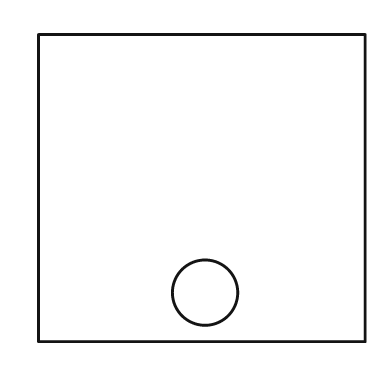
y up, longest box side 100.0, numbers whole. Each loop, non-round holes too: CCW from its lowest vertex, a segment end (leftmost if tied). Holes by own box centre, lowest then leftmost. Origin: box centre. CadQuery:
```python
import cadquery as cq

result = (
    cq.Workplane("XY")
    .moveTo(-50.0, -47.0)
    .lineTo(50.0, -47.0)
    .lineTo(50.0, 47.0)
    .lineTo(-50.0, 47.0)
    .close()
    .moveTo(1.0, -32.0)
    .circle(10.0)
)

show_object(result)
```